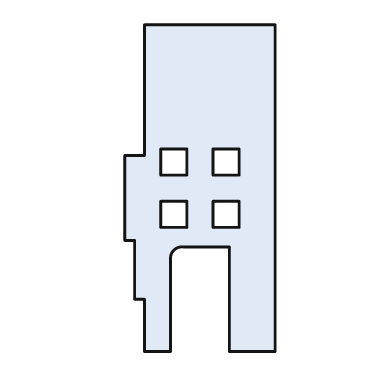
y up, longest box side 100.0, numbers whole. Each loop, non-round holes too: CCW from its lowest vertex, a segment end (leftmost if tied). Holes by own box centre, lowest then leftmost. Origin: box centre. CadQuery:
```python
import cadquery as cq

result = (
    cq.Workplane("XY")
    .moveTo(-17.0, -50.0)
    .lineTo(-9.0, -50.0)
    .lineTo(-9.0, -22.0)
    .threePointArc((-8.0, -19.0), (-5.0, -18.0))
    .lineTo(9.0, -18.0)
    .lineTo(9.0, -50.0)
    .lineTo(23.0, -50.0)
    .lineTo(23.0, 50.0)
    .lineTo(-17.0, 50.0)
    .lineTo(-17.0, 10.0)
    .lineTo(-23.0, 10.0)
    .lineTo(-23.0, -16.0)
    .lineTo(-20.0, -16.0)
    .lineTo(-20.0, -34.0)
    .lineTo(-17.0, -34.0)
    .close()
    .moveTo(-12.0, -12.0)
    .lineTo(-4.0, -12.0)
    .lineTo(-4.0, -4.0)
    .lineTo(-12.0, -4.0)
    .close()
    .moveTo(4.0, -12.0)
    .lineTo(12.0, -12.0)
    .lineTo(12.0, -4.0)
    .lineTo(4.0, -4.0)
    .close()
    .moveTo(-12.0, 4.0)
    .lineTo(-4.0, 4.0)
    .lineTo(-4.0, 12.0)
    .lineTo(-12.0, 12.0)
    .close()
    .moveTo(4.0, 4.0)
    .lineTo(12.0, 4.0)
    .lineTo(12.0, 12.0)
    .lineTo(4.0, 12.0)
    .close()
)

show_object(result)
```